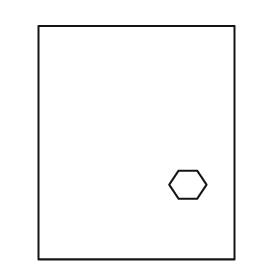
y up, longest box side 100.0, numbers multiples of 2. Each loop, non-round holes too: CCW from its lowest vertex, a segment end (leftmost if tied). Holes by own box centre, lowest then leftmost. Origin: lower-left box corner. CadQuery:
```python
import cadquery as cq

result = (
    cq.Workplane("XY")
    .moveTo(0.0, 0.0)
    .lineTo(84.0, 0.0)
    .lineTo(84.0, 100.0)
    .lineTo(0.0, 100.0)
    .close()
    .moveTo(60.0, 26.0)
    .lineTo(68.0, 26.0)
    .lineTo(72.0, 32.0)
    .lineTo(68.0, 38.0)
    .lineTo(60.0, 38.0)
    .lineTo(56.0, 32.0)
    .close()
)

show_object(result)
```